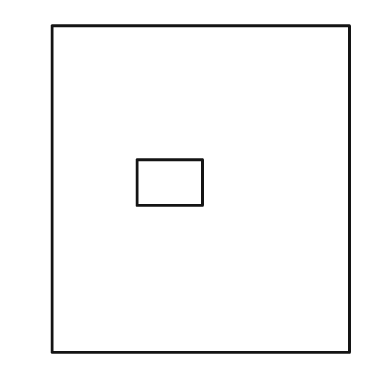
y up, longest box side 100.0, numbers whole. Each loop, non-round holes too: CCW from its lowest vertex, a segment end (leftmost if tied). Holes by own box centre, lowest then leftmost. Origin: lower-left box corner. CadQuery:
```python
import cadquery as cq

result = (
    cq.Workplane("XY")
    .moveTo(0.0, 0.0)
    .lineTo(91.0, 0.0)
    .lineTo(91.0, 100.0)
    .lineTo(0.0, 100.0)
    .close()
    .moveTo(26.0, 45.0)
    .lineTo(46.0, 45.0)
    .lineTo(46.0, 59.0)
    .lineTo(26.0, 59.0)
    .close()
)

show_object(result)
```